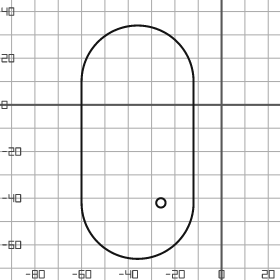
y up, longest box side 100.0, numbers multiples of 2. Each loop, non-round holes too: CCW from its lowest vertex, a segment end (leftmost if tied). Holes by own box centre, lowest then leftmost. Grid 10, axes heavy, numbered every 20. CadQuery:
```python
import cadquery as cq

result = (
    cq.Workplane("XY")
    .moveTo(-60.0, -42.0)
    .threePointArc((-36.0, -66.0), (-12.0, -42.0))
    .lineTo(-12.0, 10.0)
    .threePointArc((-36.0, 34.0), (-60.0, 10.0))
    .close()
    .moveTo(-26.0, -42.0)
    .circle(2.0)
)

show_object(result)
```